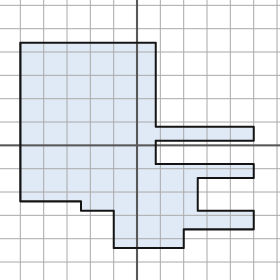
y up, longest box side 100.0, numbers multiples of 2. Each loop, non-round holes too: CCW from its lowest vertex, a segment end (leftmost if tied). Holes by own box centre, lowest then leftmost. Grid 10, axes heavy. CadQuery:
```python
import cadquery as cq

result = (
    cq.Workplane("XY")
    .moveTo(-10.0, -44.0)
    .lineTo(20.0, -44.0)
    .lineTo(20.0, -36.0)
    .lineTo(50.0, -36.0)
    .lineTo(50.0, -28.0)
    .lineTo(26.0, -28.0)
    .lineTo(26.0, -14.0)
    .lineTo(50.0, -14.0)
    .lineTo(50.0, -8.0)
    .lineTo(8.0, -8.0)
    .lineTo(8.0, 2.0)
    .lineTo(50.0, 2.0)
    .lineTo(50.0, 8.0)
    .lineTo(8.0, 8.0)
    .lineTo(8.0, 44.0)
    .lineTo(-50.0, 44.0)
    .lineTo(-50.0, -24.0)
    .lineTo(-24.0, -24.0)
    .lineTo(-24.0, -28.0)
    .lineTo(-10.0, -28.0)
    .close()
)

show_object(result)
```